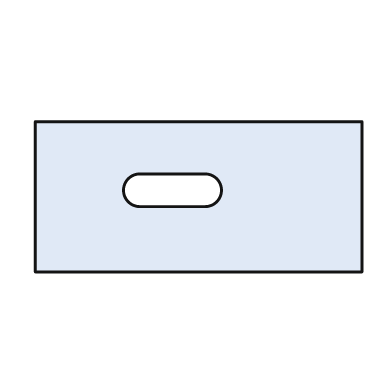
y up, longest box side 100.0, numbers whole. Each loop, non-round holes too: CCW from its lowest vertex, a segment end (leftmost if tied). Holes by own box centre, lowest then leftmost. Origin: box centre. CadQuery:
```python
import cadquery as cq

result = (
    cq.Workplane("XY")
    .moveTo(-50.0, -23.0)
    .lineTo(50.0, -23.0)
    .lineTo(50.0, 23.0)
    .lineTo(-50.0, 23.0)
    .close()
    .moveTo(-18.0, -3.0)
    .lineTo(2.0, -3.0)
    .threePointArc((7.0, 2.0), (2.0, 7.0))
    .lineTo(-18.0, 7.0)
    .threePointArc((-23.0, 2.0), (-18.0, -3.0))
    .close()
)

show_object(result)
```